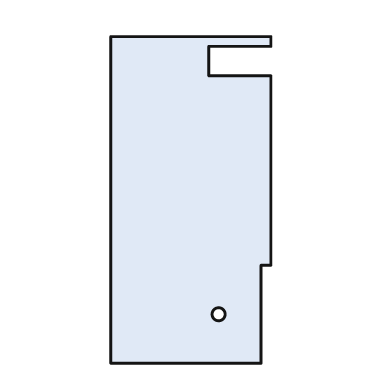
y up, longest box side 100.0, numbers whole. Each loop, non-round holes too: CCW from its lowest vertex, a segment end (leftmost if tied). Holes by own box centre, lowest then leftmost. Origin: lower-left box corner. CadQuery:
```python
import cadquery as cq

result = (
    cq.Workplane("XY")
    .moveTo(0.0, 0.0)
    .lineTo(46.0, 0.0)
    .lineTo(46.0, 30.0)
    .lineTo(49.0, 30.0)
    .lineTo(49.0, 88.0)
    .lineTo(30.0, 88.0)
    .lineTo(30.0, 97.0)
    .lineTo(49.0, 97.0)
    .lineTo(49.0, 100.0)
    .lineTo(0.0, 100.0)
    .close()
    .moveTo(33.0, 15.0)
    .circle(2.0)
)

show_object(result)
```